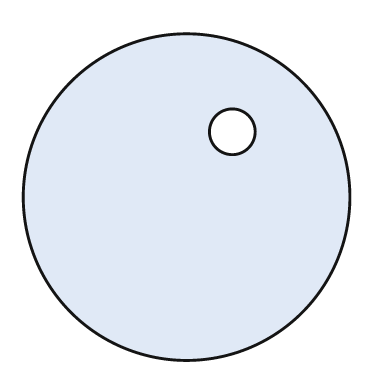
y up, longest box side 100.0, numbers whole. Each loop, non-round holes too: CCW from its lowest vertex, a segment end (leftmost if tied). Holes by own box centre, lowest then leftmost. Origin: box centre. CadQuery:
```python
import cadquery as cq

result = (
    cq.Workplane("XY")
    .moveTo(0.0, 0.0)
    .circle(50.0)
    .moveTo(14.0, 20.0)
    .circle(7.0)
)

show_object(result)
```